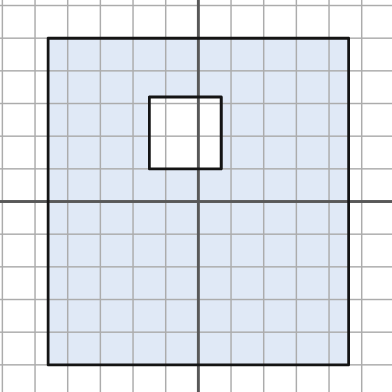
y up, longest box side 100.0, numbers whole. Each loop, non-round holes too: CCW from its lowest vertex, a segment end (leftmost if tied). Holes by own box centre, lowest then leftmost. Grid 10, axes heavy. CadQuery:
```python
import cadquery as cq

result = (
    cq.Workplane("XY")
    .moveTo(-46.0, -50.0)
    .lineTo(46.0, -50.0)
    .lineTo(46.0, 50.0)
    .lineTo(-46.0, 50.0)
    .close()
    .moveTo(-15.0, 10.0)
    .lineTo(7.0, 10.0)
    .lineTo(7.0, 32.0)
    .lineTo(-15.0, 32.0)
    .close()
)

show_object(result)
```